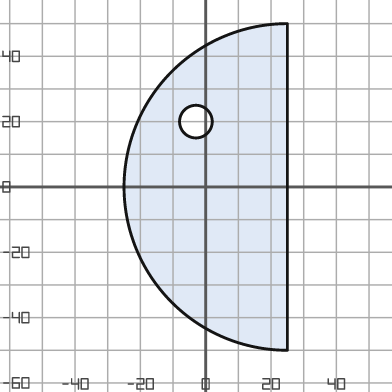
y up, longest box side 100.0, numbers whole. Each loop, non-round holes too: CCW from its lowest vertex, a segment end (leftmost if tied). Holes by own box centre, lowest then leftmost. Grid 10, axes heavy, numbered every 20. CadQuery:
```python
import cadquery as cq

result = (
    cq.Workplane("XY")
    .moveTo(25.0, -50.0)
    .lineTo(25.0, 50.0)
    .threePointArc((-25.0, 0.0), (25.0, -50.0))
    .close()
    .moveTo(-3.0, 20.0)
    .circle(5.0)
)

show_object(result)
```